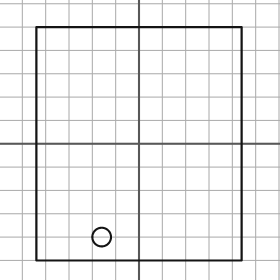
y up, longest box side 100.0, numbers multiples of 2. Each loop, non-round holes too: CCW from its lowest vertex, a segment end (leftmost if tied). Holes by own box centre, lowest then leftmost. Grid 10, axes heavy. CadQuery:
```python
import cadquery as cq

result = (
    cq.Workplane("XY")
    .moveTo(-44.0, -50.0)
    .lineTo(44.0, -50.0)
    .lineTo(44.0, 50.0)
    .lineTo(-44.0, 50.0)
    .close()
    .moveTo(-16.0, -40.0)
    .circle(4.0)
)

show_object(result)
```